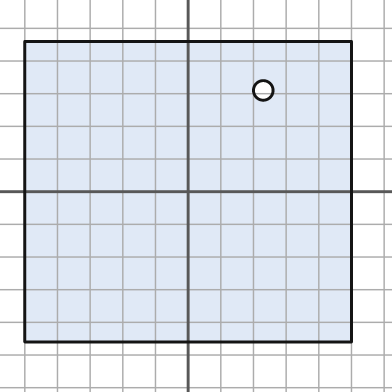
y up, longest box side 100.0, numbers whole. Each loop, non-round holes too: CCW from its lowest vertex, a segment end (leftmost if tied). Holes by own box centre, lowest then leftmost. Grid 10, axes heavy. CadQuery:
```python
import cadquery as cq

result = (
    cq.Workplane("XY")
    .moveTo(-50.0, -46.0)
    .lineTo(50.0, -46.0)
    .lineTo(50.0, 46.0)
    .lineTo(-50.0, 46.0)
    .close()
    .moveTo(23.0, 31.0)
    .circle(3.0)
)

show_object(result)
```